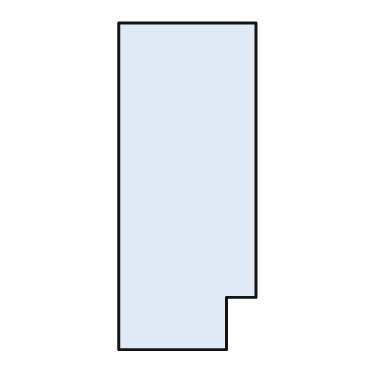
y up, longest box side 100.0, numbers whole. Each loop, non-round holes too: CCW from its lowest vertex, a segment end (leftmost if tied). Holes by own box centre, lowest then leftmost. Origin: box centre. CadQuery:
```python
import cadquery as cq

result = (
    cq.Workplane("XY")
    .moveTo(-21.0, -50.0)
    .lineTo(12.0, -50.0)
    .lineTo(12.0, -34.0)
    .lineTo(21.0, -34.0)
    .lineTo(21.0, 50.0)
    .lineTo(-21.0, 50.0)
    .close()
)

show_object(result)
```